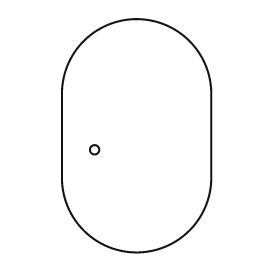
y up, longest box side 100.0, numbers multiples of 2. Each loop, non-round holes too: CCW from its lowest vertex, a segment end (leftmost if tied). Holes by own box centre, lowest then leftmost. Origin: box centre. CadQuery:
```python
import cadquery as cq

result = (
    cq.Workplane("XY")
    .moveTo(-32.0, -18.0)
    .threePointArc((0.0, -50.0), (32.0, -18.0))
    .lineTo(32.0, 18.0)
    .threePointArc((0.0, 50.0), (-32.0, 18.0))
    .close()
    .moveTo(-18.0, -6.0)
    .circle(2.0)
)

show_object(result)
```